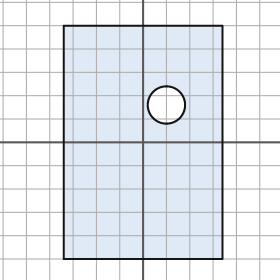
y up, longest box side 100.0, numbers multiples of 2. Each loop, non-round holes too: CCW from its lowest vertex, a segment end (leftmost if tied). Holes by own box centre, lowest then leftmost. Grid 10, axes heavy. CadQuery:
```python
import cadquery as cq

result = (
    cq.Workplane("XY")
    .moveTo(-34.0, -50.0)
    .lineTo(34.0, -50.0)
    .lineTo(34.0, 50.0)
    .lineTo(-34.0, 50.0)
    .close()
    .moveTo(10.0, 16.0)
    .circle(8.0)
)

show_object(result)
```